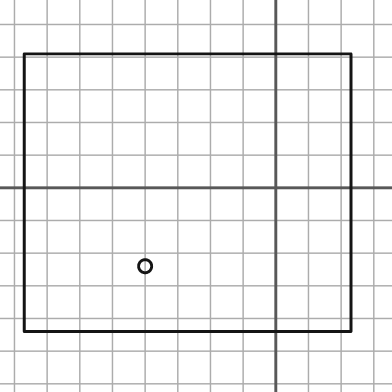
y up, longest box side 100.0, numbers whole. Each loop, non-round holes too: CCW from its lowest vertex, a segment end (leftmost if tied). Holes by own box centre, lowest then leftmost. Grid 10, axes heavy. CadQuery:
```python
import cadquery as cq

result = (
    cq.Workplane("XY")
    .moveTo(-77.0, -44.0)
    .lineTo(23.0, -44.0)
    .lineTo(23.0, 41.0)
    .lineTo(-77.0, 41.0)
    .close()
    .moveTo(-40.0, -24.0)
    .circle(2.0)
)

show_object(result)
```